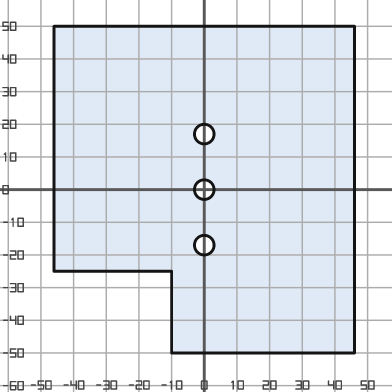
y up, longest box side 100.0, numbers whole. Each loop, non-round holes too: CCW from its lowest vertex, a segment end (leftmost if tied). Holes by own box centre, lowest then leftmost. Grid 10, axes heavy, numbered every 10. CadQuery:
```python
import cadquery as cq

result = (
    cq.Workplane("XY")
    .moveTo(-10.0, -50.0)
    .lineTo(46.0, -50.0)
    .lineTo(46.0, 50.0)
    .lineTo(-46.0, 50.0)
    .lineTo(-46.0, -25.0)
    .lineTo(-10.0, -25.0)
    .close()
    .moveTo(0.0, -17.0)
    .circle(3.0)
    .moveTo(0.0, 0.0)
    .circle(3.0)
    .moveTo(0.0, 17.0)
    .circle(3.0)
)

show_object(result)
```